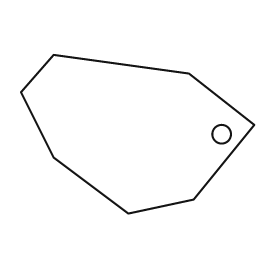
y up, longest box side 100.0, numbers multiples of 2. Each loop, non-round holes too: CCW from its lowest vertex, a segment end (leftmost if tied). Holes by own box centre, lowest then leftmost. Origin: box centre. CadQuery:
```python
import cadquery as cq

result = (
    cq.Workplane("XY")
    .moveTo(-4.0, -34.0)
    .lineTo(24.0, -28.0)
    .lineTo(50.0, 4.0)
    .lineTo(22.0, 26.0)
    .lineTo(-36.0, 34.0)
    .lineTo(-50.0, 18.0)
    .lineTo(-36.0, -10.0)
    .close()
    .moveTo(36.0, 0.0)
    .circle(4.0)
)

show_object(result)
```